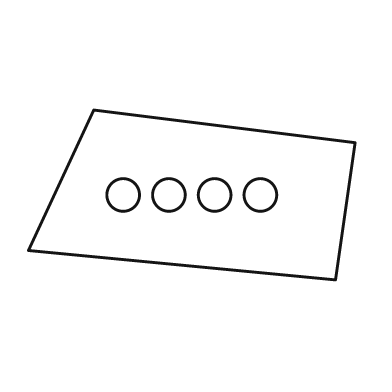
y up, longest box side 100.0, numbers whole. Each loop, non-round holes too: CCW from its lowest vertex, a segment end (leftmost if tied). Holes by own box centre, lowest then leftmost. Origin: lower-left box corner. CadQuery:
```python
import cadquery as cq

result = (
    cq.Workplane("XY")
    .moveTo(94.0, 0.0)
    .lineTo(100.0, 42.0)
    .lineTo(20.0, 52.0)
    .lineTo(0.0, 9.0)
    .close()
    .moveTo(29.0, 26.0)
    .circle(5.0)
    .moveTo(43.0, 26.0)
    .circle(5.0)
    .moveTo(57.0, 26.0)
    .circle(5.0)
    .moveTo(71.0, 26.0)
    .circle(5.0)
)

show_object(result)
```